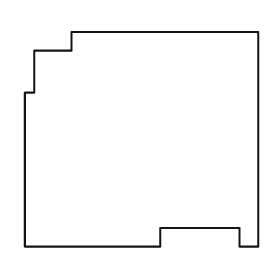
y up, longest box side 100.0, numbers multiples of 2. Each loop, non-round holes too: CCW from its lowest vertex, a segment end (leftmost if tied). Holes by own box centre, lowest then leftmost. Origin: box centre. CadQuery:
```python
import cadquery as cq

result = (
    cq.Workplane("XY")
    .moveTo(-50.0, -46.0)
    .lineTo(8.0, -46.0)
    .lineTo(8.0, -38.0)
    .lineTo(42.0, -38.0)
    .lineTo(42.0, -46.0)
    .lineTo(50.0, -46.0)
    .lineTo(50.0, 46.0)
    .lineTo(-30.0, 46.0)
    .lineTo(-30.0, 38.0)
    .lineTo(-46.0, 38.0)
    .lineTo(-46.0, 20.0)
    .lineTo(-50.0, 20.0)
    .close()
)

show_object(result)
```